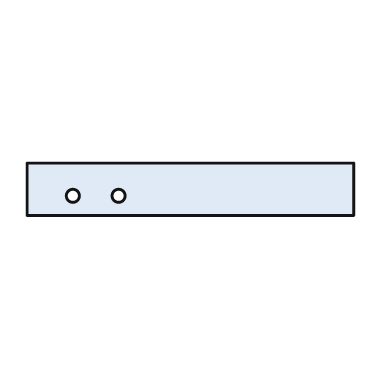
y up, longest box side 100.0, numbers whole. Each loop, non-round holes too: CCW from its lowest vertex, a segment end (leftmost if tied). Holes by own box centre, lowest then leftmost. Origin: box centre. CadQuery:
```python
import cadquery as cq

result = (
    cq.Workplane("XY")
    .moveTo(-50.0, -8.0)
    .lineTo(50.0, -8.0)
    .lineTo(50.0, 8.0)
    .lineTo(-50.0, 8.0)
    .close()
    .moveTo(-36.0, -2.0)
    .circle(2.0)
    .moveTo(-22.0, -2.0)
    .circle(2.0)
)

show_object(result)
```